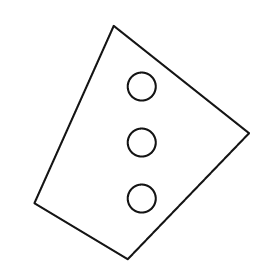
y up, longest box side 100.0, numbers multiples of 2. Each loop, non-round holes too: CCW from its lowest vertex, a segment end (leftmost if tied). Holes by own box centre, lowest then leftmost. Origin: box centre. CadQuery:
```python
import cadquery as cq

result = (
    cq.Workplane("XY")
    .moveTo(-6.0, -50.0)
    .lineTo(46.0, 4.0)
    .lineTo(-12.0, 50.0)
    .lineTo(-46.0, -26.0)
    .close()
    .moveTo(0.0, -24.0)
    .circle(6.0)
    .moveTo(0.0, 0.0)
    .circle(6.0)
    .moveTo(0.0, 24.0)
    .circle(6.0)
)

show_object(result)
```